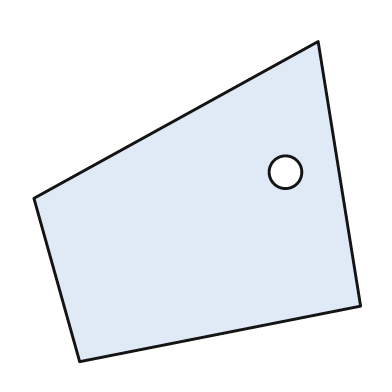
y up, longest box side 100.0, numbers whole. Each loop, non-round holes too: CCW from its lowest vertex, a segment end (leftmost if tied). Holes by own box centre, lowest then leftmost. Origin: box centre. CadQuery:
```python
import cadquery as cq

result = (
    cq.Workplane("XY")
    .moveTo(-36.0, -49.0)
    .lineTo(50.0, -32.0)
    .lineTo(37.0, 49.0)
    .lineTo(-50.0, 1.0)
    .close()
    .moveTo(27.0, 9.0)
    .circle(5.0)
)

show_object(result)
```